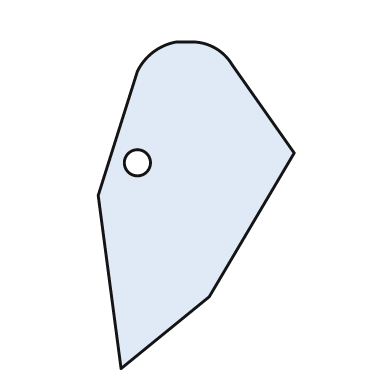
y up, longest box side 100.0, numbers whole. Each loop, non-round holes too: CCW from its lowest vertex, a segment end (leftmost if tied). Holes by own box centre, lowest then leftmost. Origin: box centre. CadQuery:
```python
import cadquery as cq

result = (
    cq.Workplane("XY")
    .moveTo(-23.0, -50.0)
    .lineTo(4.0, -28.0)
    .lineTo(30.0, 16.0)
    .lineTo(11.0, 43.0)
    .threePointArc((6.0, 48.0), (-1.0, 50.0))
    .lineTo(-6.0, 50.0)
    .threePointArc((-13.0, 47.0), (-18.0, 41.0))
    .lineTo(-30.0, 3.0)
    .close()
    .moveTo(-18.0, 13.0)
    .circle(4.0)
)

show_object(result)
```